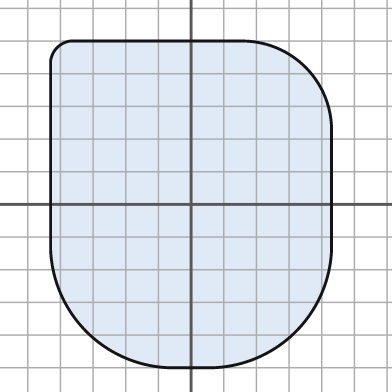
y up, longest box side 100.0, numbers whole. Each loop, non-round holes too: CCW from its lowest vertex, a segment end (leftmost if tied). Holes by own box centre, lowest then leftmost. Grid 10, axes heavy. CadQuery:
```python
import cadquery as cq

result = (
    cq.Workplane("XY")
    .moveTo(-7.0, -50.0)
    .lineTo(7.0, -50.0)
    .threePointArc((32.0, -39.0), (43.0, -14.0))
    .lineTo(43.0, 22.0)
    .threePointArc((35.0, 42.0), (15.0, 50.0))
    .lineTo(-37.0, 50.0)
    .threePointArc((-41.0, 48.0), (-43.0, 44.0))
    .lineTo(-43.0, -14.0)
    .threePointArc((-32.0, -39.0), (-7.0, -50.0))
    .close()
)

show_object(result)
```